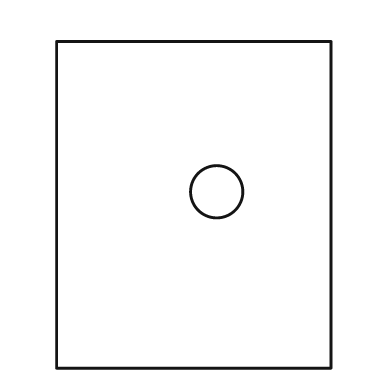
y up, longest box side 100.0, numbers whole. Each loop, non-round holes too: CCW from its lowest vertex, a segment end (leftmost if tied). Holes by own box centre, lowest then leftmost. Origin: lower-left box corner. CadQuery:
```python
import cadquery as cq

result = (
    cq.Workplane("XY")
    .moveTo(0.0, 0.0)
    .lineTo(84.0, 0.0)
    .lineTo(84.0, 100.0)
    .lineTo(0.0, 100.0)
    .close()
    .moveTo(49.0, 54.0)
    .circle(8.0)
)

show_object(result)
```